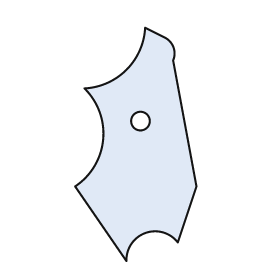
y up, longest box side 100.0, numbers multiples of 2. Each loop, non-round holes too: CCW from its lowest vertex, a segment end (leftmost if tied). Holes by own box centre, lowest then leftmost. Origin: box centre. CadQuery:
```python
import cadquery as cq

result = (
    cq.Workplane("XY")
    .moveTo(-4.0, -50.0)
    .threePointArc((4.0, -38.0), (18.0, -42.0))
    .lineTo(26.0, -18.0)
    .lineTo(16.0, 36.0)
    .threePointArc((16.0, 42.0), (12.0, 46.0))
    .lineTo(4.0, 50.0)
    .threePointArc((-4.0, 32.0), (-22.0, 24.0))
    .threePointArc((-14.0, 2.0), (-26.0, -18.0))
    .close()
    .moveTo(2.0, 10.0)
    .circle(4.0)
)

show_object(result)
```